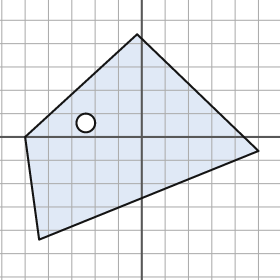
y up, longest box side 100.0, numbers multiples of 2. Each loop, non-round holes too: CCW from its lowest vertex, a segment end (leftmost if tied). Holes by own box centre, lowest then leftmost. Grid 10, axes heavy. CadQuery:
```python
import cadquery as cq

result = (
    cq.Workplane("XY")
    .moveTo(-44.0, -44.0)
    .lineTo(50.0, -6.0)
    .lineTo(-2.0, 44.0)
    .lineTo(-50.0, 0.0)
    .close()
    .moveTo(-24.0, 6.0)
    .circle(4.0)
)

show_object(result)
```